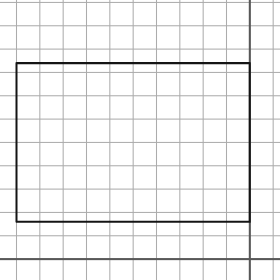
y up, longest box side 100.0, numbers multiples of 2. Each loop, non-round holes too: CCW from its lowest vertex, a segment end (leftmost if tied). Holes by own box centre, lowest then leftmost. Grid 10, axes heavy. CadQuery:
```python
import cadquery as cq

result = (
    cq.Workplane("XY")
    .moveTo(-100.0, 16.0)
    .lineTo(0.0, 16.0)
    .lineTo(0.0, 84.0)
    .lineTo(-100.0, 84.0)
    .close()
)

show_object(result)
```